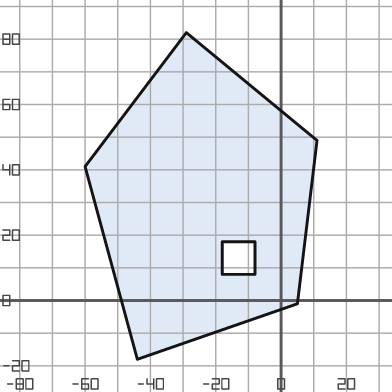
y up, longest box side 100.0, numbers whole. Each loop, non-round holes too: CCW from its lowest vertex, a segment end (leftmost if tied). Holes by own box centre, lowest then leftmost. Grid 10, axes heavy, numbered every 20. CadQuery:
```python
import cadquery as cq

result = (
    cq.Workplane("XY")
    .moveTo(-44.0, -18.0)
    .lineTo(5.0, -1.0)
    .lineTo(11.0, 49.0)
    .lineTo(-29.0, 82.0)
    .lineTo(-60.0, 41.0)
    .close()
    .moveTo(-18.0, 8.0)
    .lineTo(-8.0, 8.0)
    .lineTo(-8.0, 18.0)
    .lineTo(-18.0, 18.0)
    .close()
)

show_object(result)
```